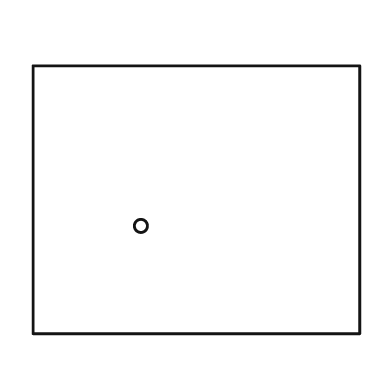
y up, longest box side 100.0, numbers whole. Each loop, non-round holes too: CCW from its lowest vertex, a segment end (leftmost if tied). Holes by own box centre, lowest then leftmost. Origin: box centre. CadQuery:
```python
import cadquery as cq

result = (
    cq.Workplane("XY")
    .moveTo(-50.0, -41.0)
    .lineTo(50.0, -41.0)
    .lineTo(50.0, 41.0)
    .lineTo(-50.0, 41.0)
    .close()
    .moveTo(-17.0, -8.0)
    .circle(2.0)
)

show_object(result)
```